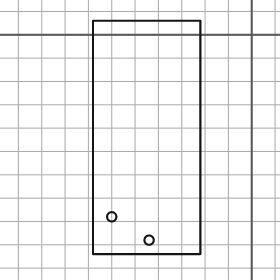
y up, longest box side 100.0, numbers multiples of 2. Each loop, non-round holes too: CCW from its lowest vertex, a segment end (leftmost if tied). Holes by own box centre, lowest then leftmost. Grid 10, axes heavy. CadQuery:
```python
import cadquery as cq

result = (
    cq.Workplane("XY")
    .moveTo(-68.0, -94.0)
    .lineTo(-22.0, -94.0)
    .lineTo(-22.0, 6.0)
    .lineTo(-68.0, 6.0)
    .close()
    .moveTo(-44.0, -88.0)
    .circle(2.0)
    .moveTo(-60.0, -78.0)
    .circle(2.0)
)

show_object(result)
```